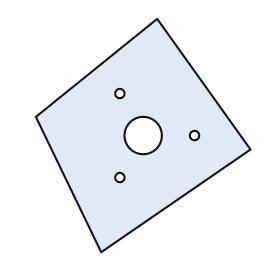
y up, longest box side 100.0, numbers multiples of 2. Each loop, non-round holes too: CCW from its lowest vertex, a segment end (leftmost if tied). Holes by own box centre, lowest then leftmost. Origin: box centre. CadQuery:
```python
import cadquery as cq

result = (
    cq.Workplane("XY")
    .moveTo(-18.0, -50.0)
    .lineTo(46.0, -6.0)
    .lineTo(6.0, 50.0)
    .lineTo(-46.0, 8.0)
    .close()
    .moveTo(-10.0, -18.0)
    .circle(2.0)
    .moveTo(0.0, 0.0)
    .circle(8.0)
    .moveTo(22.0, 0.0)
    .circle(2.0)
    .moveTo(-10.0, 18.0)
    .circle(2.0)
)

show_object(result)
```